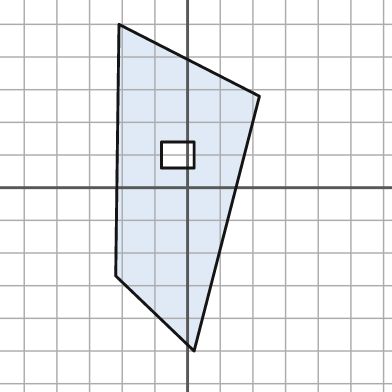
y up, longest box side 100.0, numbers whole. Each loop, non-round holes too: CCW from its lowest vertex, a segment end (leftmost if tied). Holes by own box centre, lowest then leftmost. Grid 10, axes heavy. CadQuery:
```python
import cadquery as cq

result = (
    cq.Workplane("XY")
    .moveTo(2.0, -50.0)
    .lineTo(22.0, 28.0)
    .lineTo(-21.0, 50.0)
    .lineTo(-22.0, -27.0)
    .close()
    .moveTo(-8.0, 6.0)
    .lineTo(2.0, 6.0)
    .lineTo(2.0, 14.0)
    .lineTo(-8.0, 14.0)
    .close()
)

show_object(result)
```